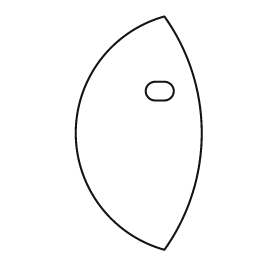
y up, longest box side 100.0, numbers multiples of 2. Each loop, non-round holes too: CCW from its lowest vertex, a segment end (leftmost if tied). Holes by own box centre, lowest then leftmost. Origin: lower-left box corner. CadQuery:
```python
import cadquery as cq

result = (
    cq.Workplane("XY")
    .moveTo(38.0, 0.0)
    .threePointArc((54.0, 50.0), (38.0, 100.0))
    .threePointArc((0.0, 50.0), (38.0, 0.0))
    .close()
    .moveTo(34.0, 64.0)
    .lineTo(38.0, 64.0)
    .threePointArc((42.0, 68.0), (38.0, 72.0))
    .lineTo(34.0, 72.0)
    .threePointArc((30.0, 68.0), (34.0, 64.0))
    .close()
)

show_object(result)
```